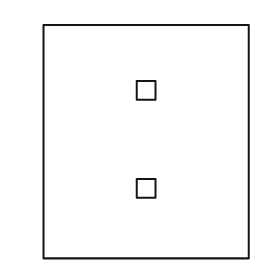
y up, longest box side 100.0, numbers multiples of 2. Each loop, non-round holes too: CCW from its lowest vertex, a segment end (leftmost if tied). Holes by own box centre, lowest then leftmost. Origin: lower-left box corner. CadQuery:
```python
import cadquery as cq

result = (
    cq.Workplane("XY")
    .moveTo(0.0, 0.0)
    .lineTo(88.0, 0.0)
    .lineTo(88.0, 100.0)
    .lineTo(0.0, 100.0)
    .close()
    .moveTo(40.0, 26.0)
    .lineTo(48.0, 26.0)
    .lineTo(48.0, 34.0)
    .lineTo(40.0, 34.0)
    .close()
    .moveTo(40.0, 68.0)
    .lineTo(48.0, 68.0)
    .lineTo(48.0, 76.0)
    .lineTo(40.0, 76.0)
    .close()
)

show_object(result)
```